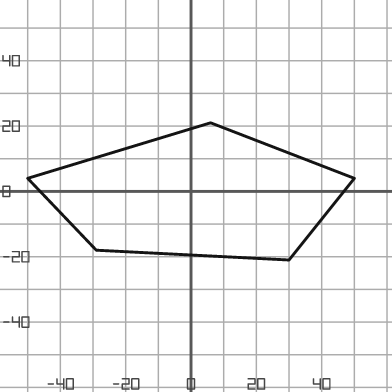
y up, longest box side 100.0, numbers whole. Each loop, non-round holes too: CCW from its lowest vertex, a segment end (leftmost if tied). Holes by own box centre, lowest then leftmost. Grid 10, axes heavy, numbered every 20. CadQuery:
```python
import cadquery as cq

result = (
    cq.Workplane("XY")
    .moveTo(30.0, -21.0)
    .lineTo(50.0, 4.0)
    .lineTo(6.0, 21.0)
    .lineTo(-50.0, 4.0)
    .lineTo(-29.0, -18.0)
    .close()
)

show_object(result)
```